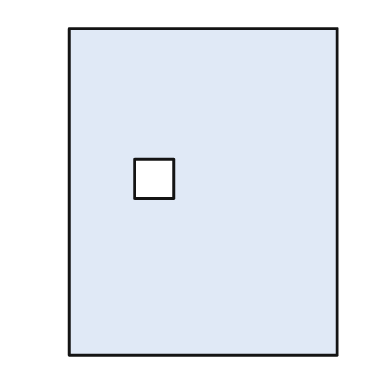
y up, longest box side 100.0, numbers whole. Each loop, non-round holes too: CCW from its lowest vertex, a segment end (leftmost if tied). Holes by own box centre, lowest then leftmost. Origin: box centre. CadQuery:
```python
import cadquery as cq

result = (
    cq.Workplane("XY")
    .moveTo(-41.0, -50.0)
    .lineTo(41.0, -50.0)
    .lineTo(41.0, 50.0)
    .lineTo(-41.0, 50.0)
    .close()
    .moveTo(-21.0, -2.0)
    .lineTo(-9.0, -2.0)
    .lineTo(-9.0, 10.0)
    .lineTo(-21.0, 10.0)
    .close()
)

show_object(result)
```